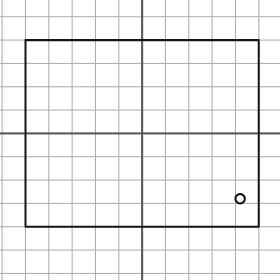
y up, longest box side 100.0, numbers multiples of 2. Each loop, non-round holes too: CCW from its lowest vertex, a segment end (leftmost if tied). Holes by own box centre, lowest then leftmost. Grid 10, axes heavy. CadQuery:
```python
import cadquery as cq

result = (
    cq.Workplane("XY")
    .moveTo(-50.0, -40.0)
    .lineTo(50.0, -40.0)
    .lineTo(50.0, 40.0)
    .lineTo(-50.0, 40.0)
    .close()
    .moveTo(42.0, -28.0)
    .circle(2.0)
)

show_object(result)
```